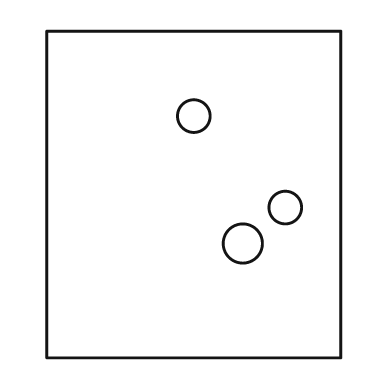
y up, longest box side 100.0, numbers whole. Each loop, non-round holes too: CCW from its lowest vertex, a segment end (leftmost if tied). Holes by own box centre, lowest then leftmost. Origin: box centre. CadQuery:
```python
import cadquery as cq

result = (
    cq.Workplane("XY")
    .moveTo(-45.0, -50.0)
    .lineTo(45.0, -50.0)
    .lineTo(45.0, 50.0)
    .lineTo(-45.0, 50.0)
    .close()
    .moveTo(15.0, -15.0)
    .circle(6.0)
    .moveTo(28.0, -4.0)
    .circle(5.0)
    .moveTo(0.0, 24.0)
    .circle(5.0)
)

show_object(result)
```